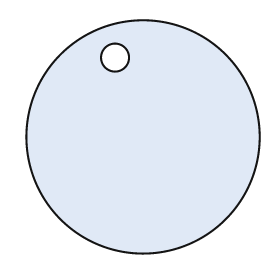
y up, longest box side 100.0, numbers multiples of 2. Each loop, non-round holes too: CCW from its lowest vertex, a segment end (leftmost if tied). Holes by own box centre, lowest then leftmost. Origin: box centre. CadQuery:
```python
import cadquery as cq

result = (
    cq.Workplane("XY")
    .moveTo(0.0, 0.0)
    .circle(50.0)
    .moveTo(-12.0, 34.0)
    .circle(6.0)
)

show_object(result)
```